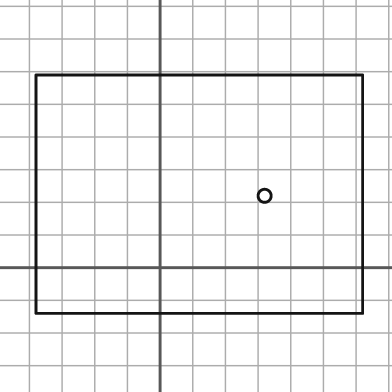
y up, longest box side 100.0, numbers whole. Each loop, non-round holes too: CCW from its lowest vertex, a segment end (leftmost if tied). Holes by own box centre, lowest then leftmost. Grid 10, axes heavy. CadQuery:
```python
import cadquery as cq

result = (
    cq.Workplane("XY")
    .moveTo(-38.0, -14.0)
    .lineTo(62.0, -14.0)
    .lineTo(62.0, 59.0)
    .lineTo(-38.0, 59.0)
    .close()
    .moveTo(32.0, 22.0)
    .circle(2.0)
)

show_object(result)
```